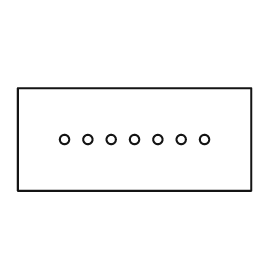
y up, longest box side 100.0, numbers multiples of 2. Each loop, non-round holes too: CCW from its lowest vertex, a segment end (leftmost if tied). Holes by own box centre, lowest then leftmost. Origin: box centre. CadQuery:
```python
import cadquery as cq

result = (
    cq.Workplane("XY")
    .moveTo(-50.0, -22.0)
    .lineTo(50.0, -22.0)
    .lineTo(50.0, 22.0)
    .lineTo(-50.0, 22.0)
    .close()
    .moveTo(-30.0, 0.0)
    .circle(2.0)
    .moveTo(-20.0, 0.0)
    .circle(2.0)
    .moveTo(-10.0, 0.0)
    .circle(2.0)
    .moveTo(0.0, 0.0)
    .circle(2.0)
    .moveTo(10.0, 0.0)
    .circle(2.0)
    .moveTo(20.0, 0.0)
    .circle(2.0)
    .moveTo(30.0, 0.0)
    .circle(2.0)
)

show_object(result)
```